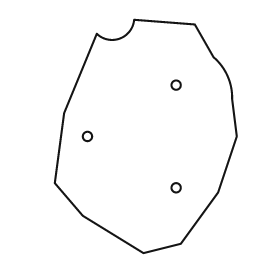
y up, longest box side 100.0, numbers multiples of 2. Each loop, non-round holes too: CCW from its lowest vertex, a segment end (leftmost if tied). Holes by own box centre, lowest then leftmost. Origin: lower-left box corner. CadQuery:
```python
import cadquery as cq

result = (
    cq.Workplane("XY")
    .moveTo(38.0, 0.0)
    .lineTo(54.0, 4.0)
    .lineTo(70.0, 26.0)
    .lineTo(78.0, 50.0)
    .lineTo(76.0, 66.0)
    .threePointArc((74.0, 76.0), (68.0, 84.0))
    .lineTo(60.0, 98.0)
    .lineTo(34.0, 100.0)
    .threePointArc((28.0, 92.0), (18.0, 94.0))
    .lineTo(4.0, 60.0)
    .lineTo(0.0, 30.0)
    .lineTo(12.0, 16.0)
    .close()
    .moveTo(52.0, 28.0)
    .circle(2.0)
    .moveTo(14.0, 50.0)
    .circle(2.0)
    .moveTo(52.0, 72.0)
    .circle(2.0)
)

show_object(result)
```